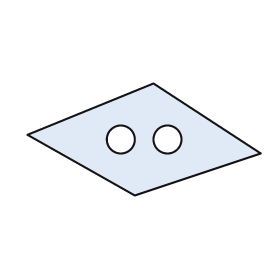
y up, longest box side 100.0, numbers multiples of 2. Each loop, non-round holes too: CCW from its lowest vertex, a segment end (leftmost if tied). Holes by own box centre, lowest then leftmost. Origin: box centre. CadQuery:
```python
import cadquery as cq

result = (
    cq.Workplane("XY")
    .moveTo(-4.0, -24.0)
    .lineTo(50.0, -6.0)
    .lineTo(4.0, 24.0)
    .lineTo(-50.0, 2.0)
    .close()
    .moveTo(-10.0, 0.0)
    .circle(6.0)
    .moveTo(10.0, 0.0)
    .circle(6.0)
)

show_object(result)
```